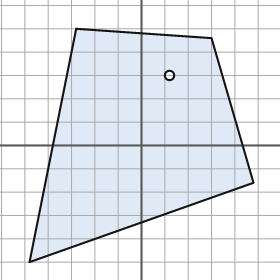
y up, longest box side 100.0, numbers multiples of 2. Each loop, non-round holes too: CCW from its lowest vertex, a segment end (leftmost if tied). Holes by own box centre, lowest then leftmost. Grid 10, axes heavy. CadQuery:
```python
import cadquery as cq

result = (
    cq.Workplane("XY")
    .moveTo(-48.0, -50.0)
    .lineTo(48.0, -16.0)
    .lineTo(30.0, 46.0)
    .lineTo(-28.0, 50.0)
    .close()
    .moveTo(12.0, 30.0)
    .circle(2.0)
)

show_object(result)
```